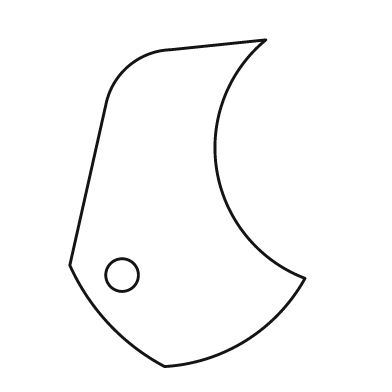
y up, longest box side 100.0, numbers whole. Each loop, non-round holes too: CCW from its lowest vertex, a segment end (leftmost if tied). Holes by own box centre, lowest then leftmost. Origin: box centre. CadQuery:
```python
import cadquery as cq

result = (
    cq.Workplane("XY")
    .moveTo(-7.0, -50.0)
    .threePointArc((18.0, -42.0), (36.0, -23.0))
    .threePointArc((9.0, 10.0), (24.0, 50.0))
    .lineTo(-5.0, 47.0)
    .threePointArc((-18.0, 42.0), (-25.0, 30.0))
    .lineTo(-36.0, -19.0)
    .threePointArc((-24.0, -37.0), (-7.0, -50.0))
    .close()
    .moveTo(-20.0, -22.0)
    .circle(5.0)
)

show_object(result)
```